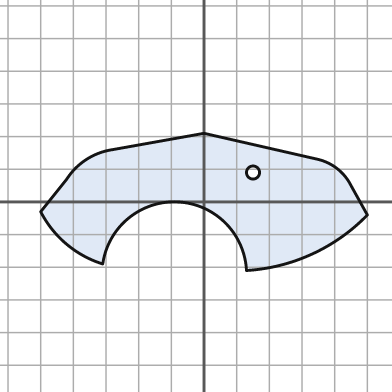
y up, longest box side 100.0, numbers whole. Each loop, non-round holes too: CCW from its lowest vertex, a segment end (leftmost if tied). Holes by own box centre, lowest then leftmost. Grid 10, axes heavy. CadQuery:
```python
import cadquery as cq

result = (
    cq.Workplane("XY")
    .moveTo(13.0, -21.0)
    .threePointArc((33.0, -16.0), (50.0, -4.0))
    .lineTo(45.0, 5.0)
    .threePointArc((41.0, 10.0), (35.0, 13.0))
    .lineTo(0.0, 21.0)
    .lineTo(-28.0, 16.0)
    .threePointArc((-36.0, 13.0), (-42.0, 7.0))
    .lineTo(-50.0, -3.0)
    .threePointArc((-42.0, -13.0), (-31.0, -19.0))
    .threePointArc((-8.0, 0.0), (13.0, -21.0))
    .close()
    .moveTo(15.0, 9.0)
    .circle(2.0)
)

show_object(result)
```